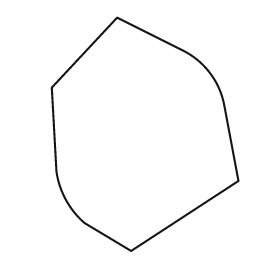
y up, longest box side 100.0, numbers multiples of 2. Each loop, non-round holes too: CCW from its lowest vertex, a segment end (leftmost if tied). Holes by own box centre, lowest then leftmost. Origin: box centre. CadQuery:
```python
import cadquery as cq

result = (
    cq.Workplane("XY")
    .moveTo(-6.0, -50.0)
    .lineTo(40.0, -20.0)
    .lineTo(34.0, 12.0)
    .threePointArc((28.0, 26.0), (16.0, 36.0))
    .lineTo(-12.0, 50.0)
    .lineTo(-40.0, 20.0)
    .lineTo(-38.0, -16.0)
    .threePointArc((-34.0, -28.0), (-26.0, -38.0))
    .close()
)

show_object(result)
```